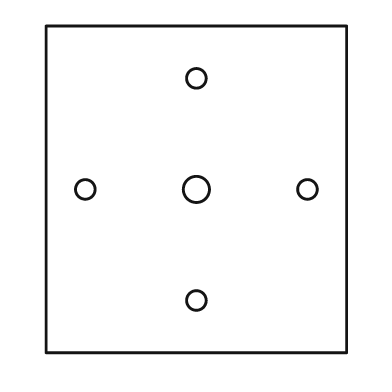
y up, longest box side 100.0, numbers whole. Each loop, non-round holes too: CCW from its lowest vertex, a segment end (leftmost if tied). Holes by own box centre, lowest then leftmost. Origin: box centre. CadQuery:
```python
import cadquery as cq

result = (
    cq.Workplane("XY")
    .moveTo(-46.0, -50.0)
    .lineTo(46.0, -50.0)
    .lineTo(46.0, 50.0)
    .lineTo(-46.0, 50.0)
    .close()
    .moveTo(0.0, -34.0)
    .circle(3.0)
    .moveTo(-34.0, 0.0)
    .circle(3.0)
    .moveTo(0.0, 0.0)
    .circle(4.0)
    .moveTo(34.0, 0.0)
    .circle(3.0)
    .moveTo(0.0, 34.0)
    .circle(3.0)
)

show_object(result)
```